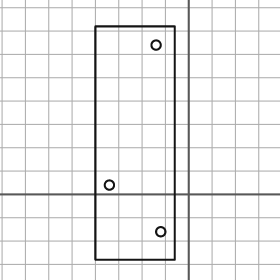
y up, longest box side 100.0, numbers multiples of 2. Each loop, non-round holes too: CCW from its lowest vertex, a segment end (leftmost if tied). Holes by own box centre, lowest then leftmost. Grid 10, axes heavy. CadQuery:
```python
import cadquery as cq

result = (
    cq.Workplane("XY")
    .moveTo(-40.0, -28.0)
    .lineTo(-6.0, -28.0)
    .lineTo(-6.0, 72.0)
    .lineTo(-40.0, 72.0)
    .close()
    .moveTo(-12.0, -16.0)
    .circle(2.0)
    .moveTo(-34.0, 4.0)
    .circle(2.0)
    .moveTo(-14.0, 64.0)
    .circle(2.0)
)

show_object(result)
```